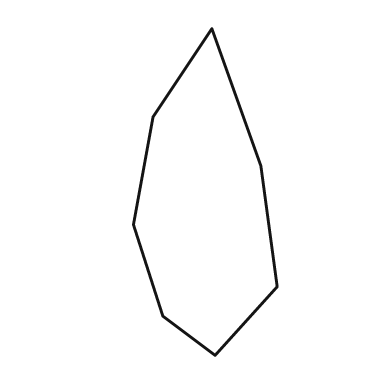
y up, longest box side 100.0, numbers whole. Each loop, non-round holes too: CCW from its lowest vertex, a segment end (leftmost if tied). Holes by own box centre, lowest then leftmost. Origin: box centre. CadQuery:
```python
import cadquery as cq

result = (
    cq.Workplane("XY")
    .moveTo(3.0, -50.0)
    .lineTo(22.0, -29.0)
    .lineTo(17.0, 8.0)
    .lineTo(2.0, 50.0)
    .lineTo(-16.0, 23.0)
    .lineTo(-22.0, -10.0)
    .lineTo(-13.0, -38.0)
    .close()
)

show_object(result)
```